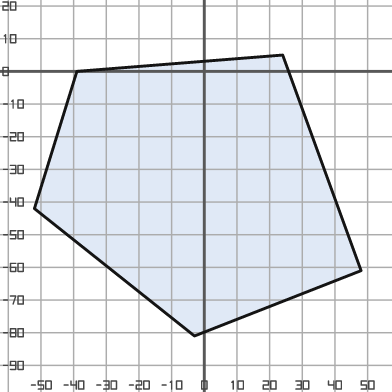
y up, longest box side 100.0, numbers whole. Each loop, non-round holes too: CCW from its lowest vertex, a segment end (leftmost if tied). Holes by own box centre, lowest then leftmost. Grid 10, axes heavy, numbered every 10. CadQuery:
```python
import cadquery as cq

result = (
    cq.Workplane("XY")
    .moveTo(-3.0, -81.0)
    .lineTo(48.0, -61.0)
    .lineTo(24.0, 5.0)
    .lineTo(-39.0, 0.0)
    .lineTo(-52.0, -42.0)
    .close()
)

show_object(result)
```